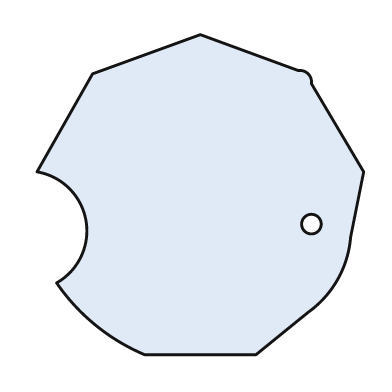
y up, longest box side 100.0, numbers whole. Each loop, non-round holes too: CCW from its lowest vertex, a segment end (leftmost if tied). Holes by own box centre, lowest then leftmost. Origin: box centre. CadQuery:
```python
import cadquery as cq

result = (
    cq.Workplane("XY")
    .moveTo(-17.0, -49.0)
    .lineTo(17.0, -49.0)
    .lineTo(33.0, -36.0)
    .threePointArc((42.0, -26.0), (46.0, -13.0))
    .lineTo(50.0, 7.0)
    .lineTo(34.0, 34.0)
    .threePointArc((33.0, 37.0), (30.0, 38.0))
    .lineTo(0.0, 49.0)
    .lineTo(-33.0, 37.0)
    .lineTo(-50.0, 7.0)
    .threePointArc((-35.0, -8.0), (-44.0, -27.0))
    .threePointArc((-32.0, -40.0), (-17.0, -49.0))
    .close()
    .moveTo(34.0, -9.0)
    .circle(3.0)
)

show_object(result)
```